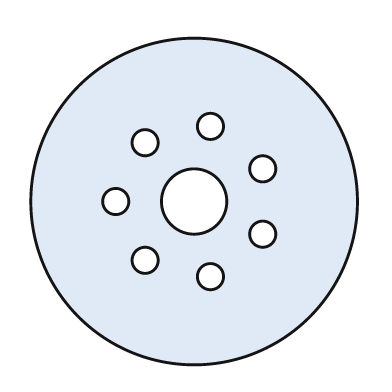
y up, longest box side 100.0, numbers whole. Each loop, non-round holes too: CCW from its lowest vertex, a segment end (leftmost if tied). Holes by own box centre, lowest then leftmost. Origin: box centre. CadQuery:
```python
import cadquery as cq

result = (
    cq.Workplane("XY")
    .moveTo(0.0, 0.0)
    .circle(50.0)
    .moveTo(5.0, -23.0)
    .circle(4.0)
    .moveTo(-15.0, -18.0)
    .circle(4.0)
    .moveTo(21.0, -10.0)
    .circle(4.0)
    .moveTo(-24.0, 0.0)
    .circle(4.0)
    .moveTo(0.0, 0.0)
    .circle(10.0)
    .moveTo(21.0, 10.0)
    .circle(4.0)
    .moveTo(-15.0, 18.0)
    .circle(4.0)
    .moveTo(5.0, 23.0)
    .circle(4.0)
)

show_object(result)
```